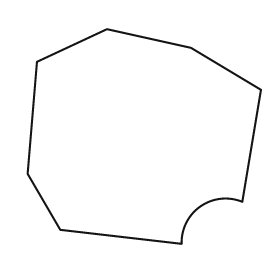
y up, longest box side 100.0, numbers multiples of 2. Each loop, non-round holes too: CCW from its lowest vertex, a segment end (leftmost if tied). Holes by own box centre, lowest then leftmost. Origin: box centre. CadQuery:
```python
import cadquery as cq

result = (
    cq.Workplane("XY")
    .moveTo(16.0, -46.0)
    .threePointArc((24.0, -30.0), (42.0, -28.0))
    .lineTo(50.0, 20.0)
    .lineTo(20.0, 38.0)
    .lineTo(-16.0, 46.0)
    .lineTo(-46.0, 32.0)
    .lineTo(-50.0, -16.0)
    .lineTo(-36.0, -40.0)
    .close()
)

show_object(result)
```